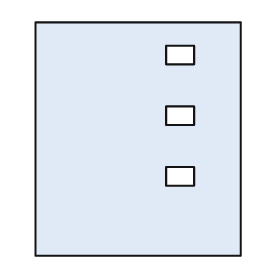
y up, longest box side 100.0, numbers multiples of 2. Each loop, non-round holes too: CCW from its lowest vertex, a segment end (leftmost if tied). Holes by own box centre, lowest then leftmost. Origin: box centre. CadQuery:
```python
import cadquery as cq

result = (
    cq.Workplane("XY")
    .moveTo(-44.0, -50.0)
    .lineTo(44.0, -50.0)
    .lineTo(44.0, 50.0)
    .lineTo(-44.0, 50.0)
    .close()
    .moveTo(12.0, -20.0)
    .lineTo(24.0, -20.0)
    .lineTo(24.0, -12.0)
    .lineTo(12.0, -12.0)
    .close()
    .moveTo(12.0, 6.0)
    .lineTo(24.0, 6.0)
    .lineTo(24.0, 14.0)
    .lineTo(12.0, 14.0)
    .close()
    .moveTo(12.0, 32.0)
    .lineTo(24.0, 32.0)
    .lineTo(24.0, 40.0)
    .lineTo(12.0, 40.0)
    .close()
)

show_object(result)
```